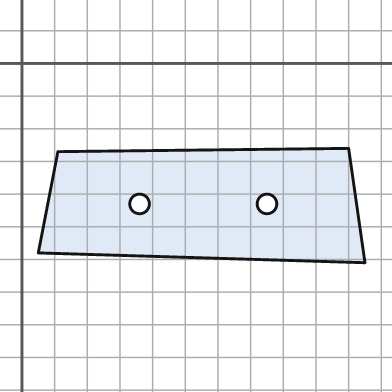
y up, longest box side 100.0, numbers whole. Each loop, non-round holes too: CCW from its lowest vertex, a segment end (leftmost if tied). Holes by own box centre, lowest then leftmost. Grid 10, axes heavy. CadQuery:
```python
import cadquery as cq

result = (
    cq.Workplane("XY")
    .moveTo(105.0, -61.0)
    .lineTo(100.0, -26.0)
    .lineTo(11.0, -27.0)
    .lineTo(5.0, -58.0)
    .close()
    .moveTo(36.0, -43.0)
    .circle(3.0)
    .moveTo(75.0, -43.0)
    .circle(3.0)
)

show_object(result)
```